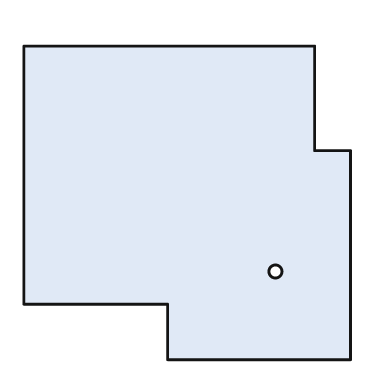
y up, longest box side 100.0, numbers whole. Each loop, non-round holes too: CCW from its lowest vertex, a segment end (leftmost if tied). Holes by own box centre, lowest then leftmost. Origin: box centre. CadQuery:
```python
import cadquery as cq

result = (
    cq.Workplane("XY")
    .moveTo(-6.0, -48.0)
    .lineTo(50.0, -48.0)
    .lineTo(50.0, 16.0)
    .lineTo(39.0, 16.0)
    .lineTo(39.0, 48.0)
    .lineTo(-50.0, 48.0)
    .lineTo(-50.0, -31.0)
    .lineTo(-6.0, -31.0)
    .close()
    .moveTo(27.0, -21.0)
    .circle(2.0)
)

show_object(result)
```